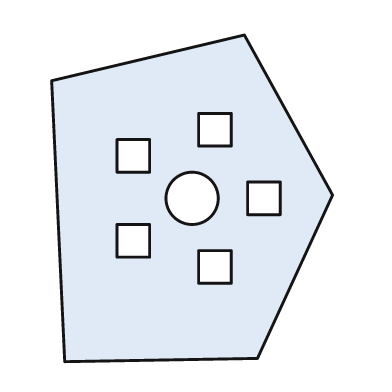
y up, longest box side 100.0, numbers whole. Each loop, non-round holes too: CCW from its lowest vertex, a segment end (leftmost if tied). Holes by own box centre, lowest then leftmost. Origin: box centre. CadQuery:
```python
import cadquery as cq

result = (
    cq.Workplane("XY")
    .moveTo(-39.0, -50.0)
    .lineTo(20.0, -49.0)
    .lineTo(43.0, 1.0)
    .lineTo(16.0, 50.0)
    .lineTo(-43.0, 36.0)
    .close()
    .moveTo(2.0, -26.0)
    .lineTo(12.0, -26.0)
    .lineTo(12.0, -16.0)
    .lineTo(2.0, -16.0)
    .close()
    .moveTo(-23.0, -18.0)
    .lineTo(-13.0, -18.0)
    .lineTo(-13.0, -8.0)
    .lineTo(-23.0, -8.0)
    .close()
    .moveTo(0.0, 0.0)
    .circle(8.0)
    .moveTo(17.0, -5.0)
    .lineTo(27.0, -5.0)
    .lineTo(27.0, 5.0)
    .lineTo(17.0, 5.0)
    .close()
    .moveTo(-23.0, 8.0)
    .lineTo(-13.0, 8.0)
    .lineTo(-13.0, 18.0)
    .lineTo(-23.0, 18.0)
    .close()
    .moveTo(2.0, 16.0)
    .lineTo(12.0, 16.0)
    .lineTo(12.0, 26.0)
    .lineTo(2.0, 26.0)
    .close()
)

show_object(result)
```